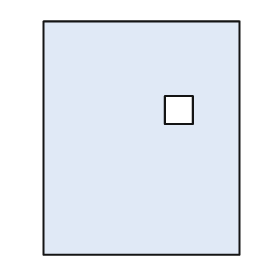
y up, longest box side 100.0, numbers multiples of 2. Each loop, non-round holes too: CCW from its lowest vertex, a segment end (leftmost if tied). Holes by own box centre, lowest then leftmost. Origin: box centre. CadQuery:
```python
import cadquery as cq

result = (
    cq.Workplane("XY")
    .moveTo(-42.0, -50.0)
    .lineTo(42.0, -50.0)
    .lineTo(42.0, 50.0)
    .lineTo(-42.0, 50.0)
    .close()
    .moveTo(10.0, 6.0)
    .lineTo(22.0, 6.0)
    .lineTo(22.0, 18.0)
    .lineTo(10.0, 18.0)
    .close()
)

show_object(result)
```